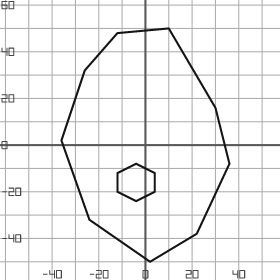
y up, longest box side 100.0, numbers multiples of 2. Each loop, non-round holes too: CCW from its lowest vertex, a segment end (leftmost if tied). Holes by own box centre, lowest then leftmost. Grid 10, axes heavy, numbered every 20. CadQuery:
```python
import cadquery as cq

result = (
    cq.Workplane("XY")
    .moveTo(2.0, -50.0)
    .lineTo(22.0, -38.0)
    .lineTo(36.0, -8.0)
    .lineTo(30.0, 16.0)
    .lineTo(10.0, 50.0)
    .lineTo(-12.0, 48.0)
    .lineTo(-26.0, 32.0)
    .lineTo(-36.0, 2.0)
    .lineTo(-24.0, -32.0)
    .close()
    .moveTo(-4.0, -24.0)
    .lineTo(4.0, -20.0)
    .lineTo(4.0, -12.0)
    .lineTo(-4.0, -8.0)
    .lineTo(-12.0, -12.0)
    .lineTo(-12.0, -20.0)
    .close()
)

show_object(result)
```